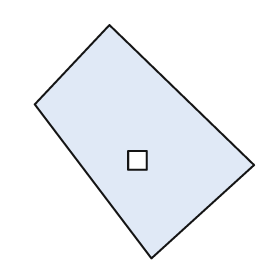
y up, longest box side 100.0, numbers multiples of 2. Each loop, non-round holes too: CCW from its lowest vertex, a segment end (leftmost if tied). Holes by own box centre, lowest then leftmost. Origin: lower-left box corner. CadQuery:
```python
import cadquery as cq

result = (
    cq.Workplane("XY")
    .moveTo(50.0, 0.0)
    .lineTo(94.0, 40.0)
    .lineTo(32.0, 100.0)
    .lineTo(0.0, 66.0)
    .close()
    .moveTo(40.0, 38.0)
    .lineTo(48.0, 38.0)
    .lineTo(48.0, 46.0)
    .lineTo(40.0, 46.0)
    .close()
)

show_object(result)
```